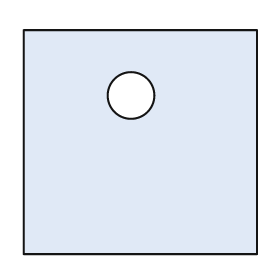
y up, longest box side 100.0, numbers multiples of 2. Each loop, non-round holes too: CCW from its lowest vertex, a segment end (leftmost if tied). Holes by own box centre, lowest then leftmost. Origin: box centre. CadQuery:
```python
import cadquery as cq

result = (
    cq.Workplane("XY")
    .moveTo(-50.0, -48.0)
    .lineTo(50.0, -48.0)
    .lineTo(50.0, 48.0)
    .lineTo(-50.0, 48.0)
    .close()
    .moveTo(-4.0, 20.0)
    .circle(10.0)
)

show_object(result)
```